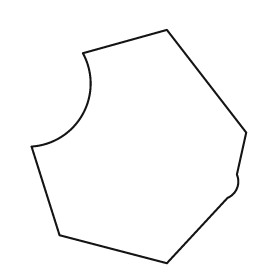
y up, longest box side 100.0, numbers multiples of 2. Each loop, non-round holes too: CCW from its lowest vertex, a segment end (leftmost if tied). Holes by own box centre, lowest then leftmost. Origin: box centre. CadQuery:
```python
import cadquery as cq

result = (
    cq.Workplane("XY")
    .moveTo(12.0, -50.0)
    .lineTo(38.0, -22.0)
    .threePointArc((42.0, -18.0), (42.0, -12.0))
    .lineTo(46.0, 6.0)
    .lineTo(12.0, 50.0)
    .lineTo(-24.0, 40.0)
    .threePointArc((-24.0, 14.0), (-46.0, 0.0))
    .lineTo(-34.0, -38.0)
    .close()
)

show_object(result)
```